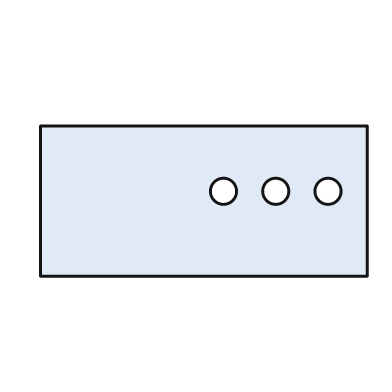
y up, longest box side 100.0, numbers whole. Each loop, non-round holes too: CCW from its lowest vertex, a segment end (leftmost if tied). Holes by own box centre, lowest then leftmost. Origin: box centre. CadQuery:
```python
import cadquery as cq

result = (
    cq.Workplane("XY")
    .moveTo(-50.0, -23.0)
    .lineTo(50.0, -23.0)
    .lineTo(50.0, 23.0)
    .lineTo(-50.0, 23.0)
    .close()
    .moveTo(6.0, 3.0)
    .circle(4.0)
    .moveTo(22.0, 3.0)
    .circle(4.0)
    .moveTo(38.0, 3.0)
    .circle(4.0)
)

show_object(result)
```